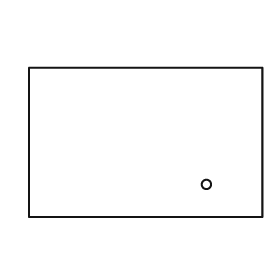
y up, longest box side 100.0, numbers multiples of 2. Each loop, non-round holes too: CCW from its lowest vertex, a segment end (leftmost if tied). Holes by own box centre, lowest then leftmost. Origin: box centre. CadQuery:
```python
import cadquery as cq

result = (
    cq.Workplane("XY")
    .moveTo(-50.0, -32.0)
    .lineTo(50.0, -32.0)
    .lineTo(50.0, 32.0)
    .lineTo(-50.0, 32.0)
    .close()
    .moveTo(26.0, -18.0)
    .circle(2.0)
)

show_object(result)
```